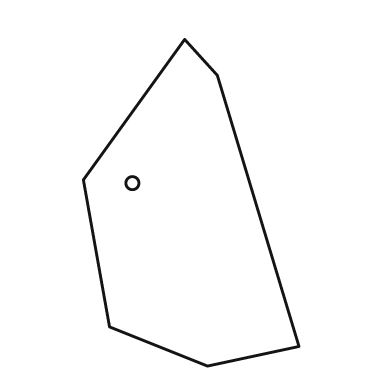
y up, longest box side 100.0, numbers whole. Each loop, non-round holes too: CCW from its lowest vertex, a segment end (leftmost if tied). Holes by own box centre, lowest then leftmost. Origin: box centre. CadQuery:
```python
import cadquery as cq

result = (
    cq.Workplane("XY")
    .moveTo(5.0, -50.0)
    .lineTo(33.0, -44.0)
    .lineTo(8.0, 39.0)
    .lineTo(-2.0, 50.0)
    .lineTo(-33.0, 7.0)
    .lineTo(-25.0, -38.0)
    .close()
    .moveTo(-18.0, 6.0)
    .circle(2.0)
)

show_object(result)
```